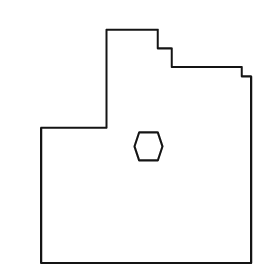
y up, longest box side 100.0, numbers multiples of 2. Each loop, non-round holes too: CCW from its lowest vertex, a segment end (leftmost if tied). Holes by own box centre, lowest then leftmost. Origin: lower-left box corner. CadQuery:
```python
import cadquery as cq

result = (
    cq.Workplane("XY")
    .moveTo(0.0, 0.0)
    .lineTo(90.0, 0.0)
    .lineTo(90.0, 80.0)
    .lineTo(86.0, 80.0)
    .lineTo(86.0, 84.0)
    .lineTo(56.0, 84.0)
    .lineTo(56.0, 92.0)
    .lineTo(50.0, 92.0)
    .lineTo(50.0, 100.0)
    .lineTo(28.0, 100.0)
    .lineTo(28.0, 58.0)
    .lineTo(0.0, 58.0)
    .close()
    .moveTo(42.0, 44.0)
    .lineTo(50.0, 44.0)
    .lineTo(52.0, 50.0)
    .lineTo(50.0, 56.0)
    .lineTo(42.0, 56.0)
    .lineTo(40.0, 50.0)
    .close()
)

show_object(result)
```